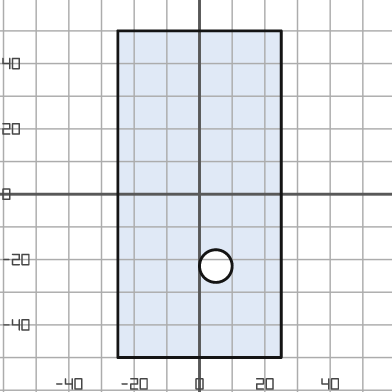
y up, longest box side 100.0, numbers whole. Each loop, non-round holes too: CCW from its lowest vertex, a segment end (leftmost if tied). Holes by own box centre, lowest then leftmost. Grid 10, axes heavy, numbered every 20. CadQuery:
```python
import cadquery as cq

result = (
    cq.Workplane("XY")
    .moveTo(-25.0, -50.0)
    .lineTo(25.0, -50.0)
    .lineTo(25.0, 50.0)
    .lineTo(-25.0, 50.0)
    .close()
    .moveTo(5.0, -22.0)
    .circle(5.0)
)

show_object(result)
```